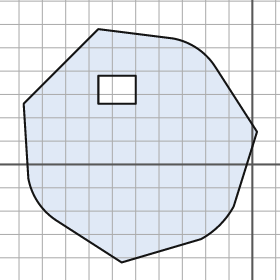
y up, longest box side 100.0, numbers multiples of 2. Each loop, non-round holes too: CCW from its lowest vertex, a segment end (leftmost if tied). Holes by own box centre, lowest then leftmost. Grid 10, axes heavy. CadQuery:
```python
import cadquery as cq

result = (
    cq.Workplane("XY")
    .moveTo(-56.0, -42.0)
    .lineTo(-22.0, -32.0)
    .threePointArc((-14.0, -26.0), (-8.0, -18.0))
    .lineTo(2.0, 14.0)
    .lineTo(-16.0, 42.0)
    .threePointArc((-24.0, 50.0), (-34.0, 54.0))
    .lineTo(-66.0, 58.0)
    .lineTo(-98.0, 26.0)
    .lineTo(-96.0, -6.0)
    .threePointArc((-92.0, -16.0), (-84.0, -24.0))
    .close()
    .moveTo(-66.0, 26.0)
    .lineTo(-50.0, 26.0)
    .lineTo(-50.0, 38.0)
    .lineTo(-66.0, 38.0)
    .close()
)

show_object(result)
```